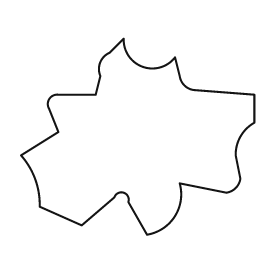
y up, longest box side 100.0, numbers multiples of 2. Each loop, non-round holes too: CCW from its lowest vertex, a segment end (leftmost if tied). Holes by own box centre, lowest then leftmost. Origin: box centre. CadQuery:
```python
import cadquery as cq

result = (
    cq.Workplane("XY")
    .moveTo(4.0, -42.0)
    .threePointArc((16.0, -34.0), (18.0, -20.0))
    .lineTo(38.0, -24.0)
    .threePointArc((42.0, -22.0), (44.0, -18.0))
    .lineTo(42.0, -8.0)
    .threePointArc((44.0, 0.0), (50.0, 6.0))
    .lineTo(50.0, 18.0)
    .lineTo(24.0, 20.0)
    .threePointArc((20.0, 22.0), (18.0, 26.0))
    .lineTo(16.0, 34.0)
    .threePointArc((2.0, 30.0), (-6.0, 42.0))
    .lineTo(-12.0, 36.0)
    .threePointArc((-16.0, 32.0), (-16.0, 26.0))
    .lineTo(-18.0, 18.0)
    .lineTo(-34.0, 18.0)
    .threePointArc((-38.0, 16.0), (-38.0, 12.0))
    .lineTo(-34.0, 2.0)
    .lineTo(-50.0, -8.0)
    .threePointArc((-44.0, -18.0), (-42.0, -30.0))
    .lineTo(-24.0, -38.0)
    .lineTo(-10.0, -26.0)
    .threePointArc((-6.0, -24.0), (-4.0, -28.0))
    .close()
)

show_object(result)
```